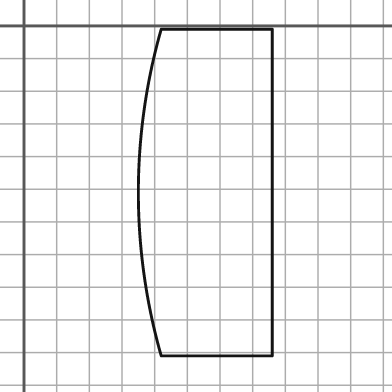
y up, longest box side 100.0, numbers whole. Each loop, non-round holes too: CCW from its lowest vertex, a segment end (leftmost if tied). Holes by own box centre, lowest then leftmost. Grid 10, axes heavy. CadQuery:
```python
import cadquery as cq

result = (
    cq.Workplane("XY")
    .moveTo(42.0, -101.0)
    .lineTo(76.0, -101.0)
    .lineTo(76.0, -1.0)
    .lineTo(42.0, -1.0)
    .threePointArc((35.0, -51.0), (42.0, -101.0))
    .close()
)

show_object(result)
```